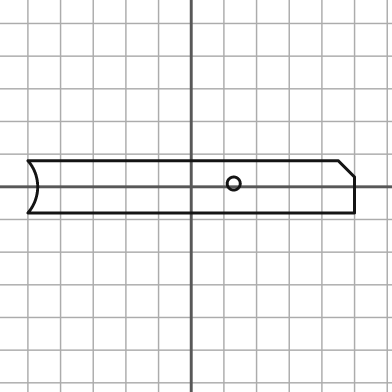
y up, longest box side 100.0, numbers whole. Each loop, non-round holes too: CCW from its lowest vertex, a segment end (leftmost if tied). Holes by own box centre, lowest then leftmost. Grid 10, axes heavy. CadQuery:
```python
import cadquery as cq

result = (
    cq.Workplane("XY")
    .moveTo(-50.0, -8.0)
    .lineTo(50.0, -8.0)
    .lineTo(50.0, 3.0)
    .lineTo(45.0, 8.0)
    .lineTo(-50.0, 8.0)
    .threePointArc((-47.0, 0.0), (-50.0, -8.0))
    .close()
    .moveTo(13.0, 1.0)
    .circle(2.0)
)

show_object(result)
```